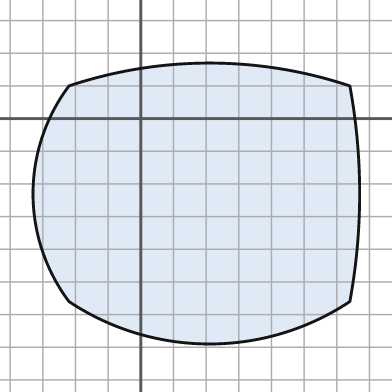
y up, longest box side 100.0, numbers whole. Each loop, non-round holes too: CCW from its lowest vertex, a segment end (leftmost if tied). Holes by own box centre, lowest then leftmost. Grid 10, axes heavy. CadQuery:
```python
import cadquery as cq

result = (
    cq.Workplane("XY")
    .moveTo(-22.0, -56.0)
    .threePointArc((21.0, -69.0), (64.0, -56.0))
    .threePointArc((67.0, -23.0), (64.0, 10.0))
    .threePointArc((21.0, 17.0), (-22.0, 10.0))
    .threePointArc((-33.0, -23.0), (-22.0, -56.0))
    .close()
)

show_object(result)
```